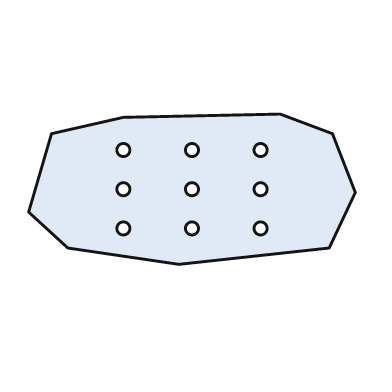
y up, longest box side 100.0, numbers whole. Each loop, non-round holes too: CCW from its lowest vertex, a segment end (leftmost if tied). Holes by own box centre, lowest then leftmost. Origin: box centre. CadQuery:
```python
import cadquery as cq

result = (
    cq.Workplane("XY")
    .moveTo(-4.0, -23.0)
    .lineTo(42.0, -18.0)
    .lineTo(50.0, -1.0)
    .lineTo(43.0, 17.0)
    .lineTo(27.0, 23.0)
    .lineTo(-21.0, 22.0)
    .lineTo(-43.0, 17.0)
    .lineTo(-50.0, -7.0)
    .lineTo(-38.0, -18.0)
    .close()
    .moveTo(-21.0, -12.0)
    .circle(2.0)
    .moveTo(0.0, -12.0)
    .circle(2.0)
    .moveTo(21.0, -12.0)
    .circle(2.0)
    .moveTo(-21.0, 0.0)
    .circle(2.0)
    .moveTo(0.0, 0.0)
    .circle(2.0)
    .moveTo(21.0, 0.0)
    .circle(2.0)
    .moveTo(-21.0, 12.0)
    .circle(2.0)
    .moveTo(0.0, 12.0)
    .circle(2.0)
    .moveTo(21.0, 12.0)
    .circle(2.0)
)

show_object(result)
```